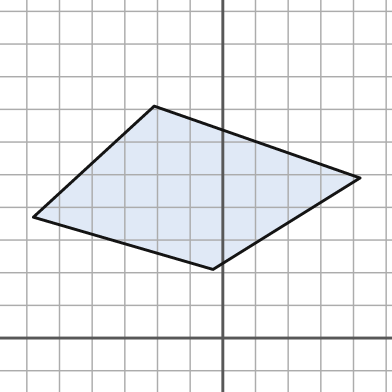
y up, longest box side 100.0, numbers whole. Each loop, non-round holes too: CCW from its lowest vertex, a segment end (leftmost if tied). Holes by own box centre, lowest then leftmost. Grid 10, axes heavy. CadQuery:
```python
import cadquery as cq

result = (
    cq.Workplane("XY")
    .moveTo(-3.0, 21.0)
    .lineTo(42.0, 49.0)
    .lineTo(-21.0, 71.0)
    .lineTo(-58.0, 37.0)
    .close()
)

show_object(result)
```